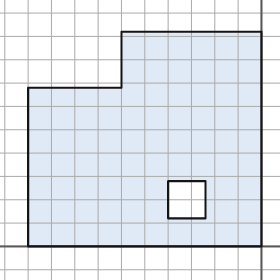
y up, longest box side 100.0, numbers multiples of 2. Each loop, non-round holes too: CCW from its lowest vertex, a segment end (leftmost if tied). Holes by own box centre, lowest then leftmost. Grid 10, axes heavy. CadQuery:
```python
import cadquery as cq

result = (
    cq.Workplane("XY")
    .moveTo(-100.0, 0.0)
    .lineTo(0.0, 0.0)
    .lineTo(0.0, 92.0)
    .lineTo(-60.0, 92.0)
    .lineTo(-60.0, 68.0)
    .lineTo(-100.0, 68.0)
    .close()
    .moveTo(-40.0, 12.0)
    .lineTo(-24.0, 12.0)
    .lineTo(-24.0, 28.0)
    .lineTo(-40.0, 28.0)
    .close()
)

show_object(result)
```